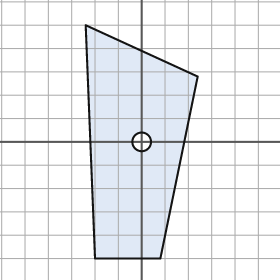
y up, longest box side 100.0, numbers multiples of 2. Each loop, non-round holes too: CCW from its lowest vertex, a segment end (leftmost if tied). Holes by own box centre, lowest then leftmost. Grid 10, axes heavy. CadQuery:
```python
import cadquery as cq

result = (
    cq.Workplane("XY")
    .moveTo(-20.0, -50.0)
    .lineTo(8.0, -50.0)
    .lineTo(24.0, 28.0)
    .lineTo(-24.0, 50.0)
    .close()
    .moveTo(0.0, 0.0)
    .circle(4.0)
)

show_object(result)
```